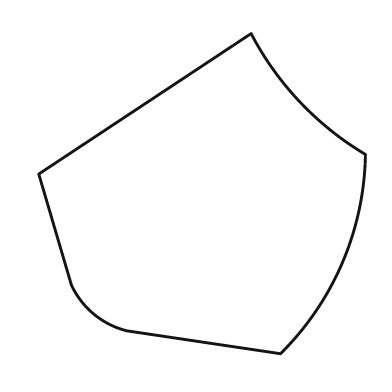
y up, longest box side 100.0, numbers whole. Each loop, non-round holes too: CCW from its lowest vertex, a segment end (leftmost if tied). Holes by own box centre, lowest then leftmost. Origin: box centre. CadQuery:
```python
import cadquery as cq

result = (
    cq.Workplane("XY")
    .moveTo(24.0, -49.0)
    .threePointArc((43.0, -21.0), (50.0, 12.0))
    .threePointArc((30.0, 28.0), (15.0, 49.0))
    .lineTo(-50.0, 6.0)
    .lineTo(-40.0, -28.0)
    .threePointArc((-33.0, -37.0), (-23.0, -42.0))
    .close()
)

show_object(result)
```